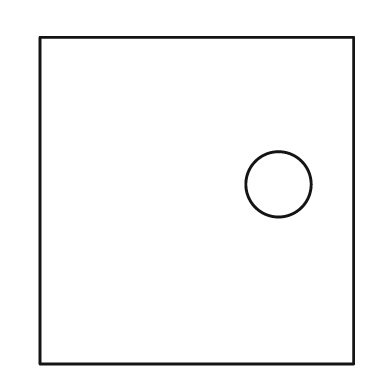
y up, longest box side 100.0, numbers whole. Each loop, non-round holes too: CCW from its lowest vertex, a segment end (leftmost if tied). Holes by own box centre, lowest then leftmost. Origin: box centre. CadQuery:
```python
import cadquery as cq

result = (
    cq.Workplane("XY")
    .moveTo(-48.0, -50.0)
    .lineTo(48.0, -50.0)
    .lineTo(48.0, 50.0)
    .lineTo(-48.0, 50.0)
    .close()
    .moveTo(25.0, 5.0)
    .circle(10.0)
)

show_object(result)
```